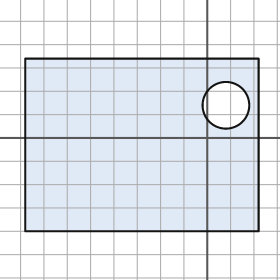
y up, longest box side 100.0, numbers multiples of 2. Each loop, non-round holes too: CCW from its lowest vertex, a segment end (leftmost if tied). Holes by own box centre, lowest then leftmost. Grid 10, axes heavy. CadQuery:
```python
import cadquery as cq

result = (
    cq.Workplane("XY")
    .moveTo(-78.0, -40.0)
    .lineTo(22.0, -40.0)
    .lineTo(22.0, 34.0)
    .lineTo(-78.0, 34.0)
    .close()
    .moveTo(8.0, 14.0)
    .circle(10.0)
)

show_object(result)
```